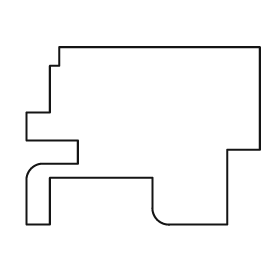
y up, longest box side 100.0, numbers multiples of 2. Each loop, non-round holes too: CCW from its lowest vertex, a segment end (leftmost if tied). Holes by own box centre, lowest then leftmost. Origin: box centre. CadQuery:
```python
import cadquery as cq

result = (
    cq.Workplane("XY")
    .moveTo(-50.0, -38.0)
    .lineTo(-40.0, -38.0)
    .lineTo(-40.0, -18.0)
    .lineTo(4.0, -18.0)
    .lineTo(4.0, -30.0)
    .threePointArc((6.0, -36.0), (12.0, -38.0))
    .lineTo(36.0, -38.0)
    .lineTo(36.0, -6.0)
    .lineTo(50.0, -6.0)
    .lineTo(50.0, 38.0)
    .lineTo(-36.0, 38.0)
    .lineTo(-36.0, 30.0)
    .lineTo(-40.0, 30.0)
    .lineTo(-40.0, 10.0)
    .lineTo(-50.0, 10.0)
    .lineTo(-50.0, -2.0)
    .lineTo(-28.0, -2.0)
    .lineTo(-28.0, -12.0)
    .lineTo(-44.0, -12.0)
    .threePointArc((-48.0, -14.0), (-50.0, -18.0))
    .close()
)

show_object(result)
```